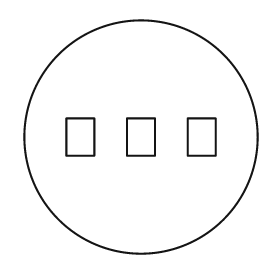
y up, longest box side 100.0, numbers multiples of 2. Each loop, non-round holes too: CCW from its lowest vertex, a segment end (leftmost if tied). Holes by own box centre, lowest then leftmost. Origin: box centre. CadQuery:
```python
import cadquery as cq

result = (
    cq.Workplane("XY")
    .moveTo(0.0, 0.0)
    .circle(50.0)
    .moveTo(-32.0, -8.0)
    .lineTo(-20.0, -8.0)
    .lineTo(-20.0, 8.0)
    .lineTo(-32.0, 8.0)
    .close()
    .moveTo(-6.0, -8.0)
    .lineTo(6.0, -8.0)
    .lineTo(6.0, 8.0)
    .lineTo(-6.0, 8.0)
    .close()
    .moveTo(20.0, -8.0)
    .lineTo(32.0, -8.0)
    .lineTo(32.0, 8.0)
    .lineTo(20.0, 8.0)
    .close()
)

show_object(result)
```